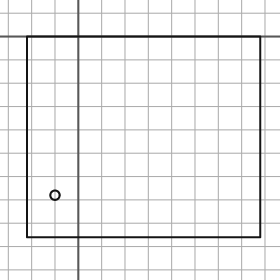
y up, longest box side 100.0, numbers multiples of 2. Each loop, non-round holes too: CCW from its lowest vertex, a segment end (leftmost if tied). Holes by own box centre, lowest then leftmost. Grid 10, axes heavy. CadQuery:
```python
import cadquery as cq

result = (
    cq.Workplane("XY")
    .moveTo(-22.0, -86.0)
    .lineTo(78.0, -86.0)
    .lineTo(78.0, 0.0)
    .lineTo(-22.0, 0.0)
    .close()
    .moveTo(-10.0, -68.0)
    .circle(2.0)
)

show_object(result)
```